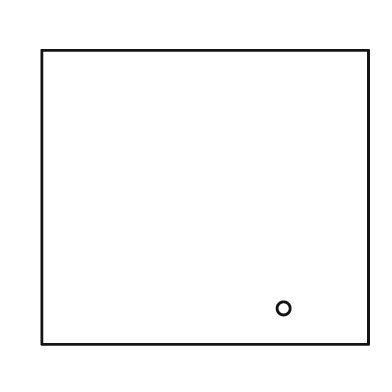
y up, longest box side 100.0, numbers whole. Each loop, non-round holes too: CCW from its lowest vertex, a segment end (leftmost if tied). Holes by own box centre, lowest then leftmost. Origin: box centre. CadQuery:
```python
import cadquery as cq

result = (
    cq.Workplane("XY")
    .moveTo(-50.0, -45.0)
    .lineTo(50.0, -45.0)
    .lineTo(50.0, 45.0)
    .lineTo(-50.0, 45.0)
    .close()
    .moveTo(24.0, -34.0)
    .circle(2.0)
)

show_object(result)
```